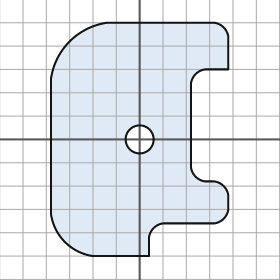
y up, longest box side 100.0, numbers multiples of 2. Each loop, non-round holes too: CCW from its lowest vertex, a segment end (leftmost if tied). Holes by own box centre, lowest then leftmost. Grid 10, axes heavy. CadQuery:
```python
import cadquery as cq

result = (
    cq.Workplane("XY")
    .moveTo(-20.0, -50.0)
    .lineTo(4.0, -50.0)
    .lineTo(4.0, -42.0)
    .threePointArc((6.0, -38.0), (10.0, -36.0))
    .lineTo(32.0, -36.0)
    .threePointArc((36.0, -34.0), (38.0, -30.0))
    .lineTo(38.0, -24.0)
    .threePointArc((36.0, -20.0), (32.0, -18.0))
    .lineTo(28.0, -18.0)
    .threePointArc((24.0, -16.0), (22.0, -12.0))
    .lineTo(22.0, 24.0)
    .threePointArc((24.0, 28.0), (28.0, 30.0))
    .lineTo(38.0, 30.0)
    .lineTo(38.0, 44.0)
    .threePointArc((36.0, 48.0), (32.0, 50.0))
    .lineTo(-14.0, 50.0)
    .threePointArc((-30.0, 42.0), (-38.0, 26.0))
    .lineTo(-38.0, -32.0)
    .threePointArc((-32.0, -44.0), (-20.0, -50.0))
    .close()
    .moveTo(0.0, 0.0)
    .circle(6.0)
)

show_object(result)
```